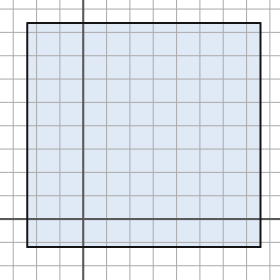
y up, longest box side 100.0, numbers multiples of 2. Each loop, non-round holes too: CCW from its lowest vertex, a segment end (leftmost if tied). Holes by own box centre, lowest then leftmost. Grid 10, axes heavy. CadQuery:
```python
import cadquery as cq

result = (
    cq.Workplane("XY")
    .moveTo(-24.0, -12.0)
    .lineTo(76.0, -12.0)
    .lineTo(76.0, 84.0)
    .lineTo(-24.0, 84.0)
    .close()
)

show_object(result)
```